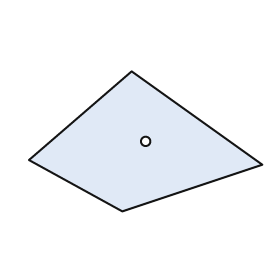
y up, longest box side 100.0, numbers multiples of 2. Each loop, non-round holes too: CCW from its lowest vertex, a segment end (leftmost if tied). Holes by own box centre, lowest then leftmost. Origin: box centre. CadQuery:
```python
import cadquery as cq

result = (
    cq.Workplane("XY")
    .moveTo(-10.0, -30.0)
    .lineTo(50.0, -10.0)
    .lineTo(-6.0, 30.0)
    .lineTo(-50.0, -8.0)
    .close()
    .moveTo(0.0, 0.0)
    .circle(2.0)
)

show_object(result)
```